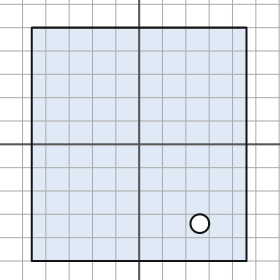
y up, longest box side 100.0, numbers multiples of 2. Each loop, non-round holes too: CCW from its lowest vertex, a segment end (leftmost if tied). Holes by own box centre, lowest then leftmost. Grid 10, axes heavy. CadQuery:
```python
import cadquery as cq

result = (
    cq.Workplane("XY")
    .moveTo(-46.0, -50.0)
    .lineTo(46.0, -50.0)
    .lineTo(46.0, 50.0)
    .lineTo(-46.0, 50.0)
    .close()
    .moveTo(26.0, -34.0)
    .circle(4.0)
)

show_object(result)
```